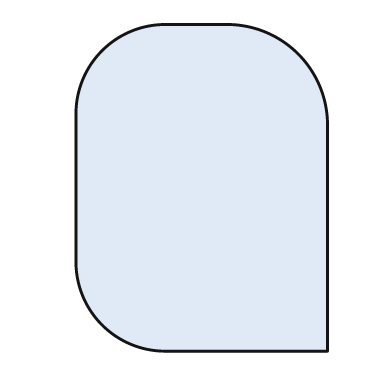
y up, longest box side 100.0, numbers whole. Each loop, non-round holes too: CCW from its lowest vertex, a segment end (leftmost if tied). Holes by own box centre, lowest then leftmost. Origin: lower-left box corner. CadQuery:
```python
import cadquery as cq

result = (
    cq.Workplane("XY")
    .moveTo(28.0, 0.0)
    .lineTo(77.0, 0.0)
    .lineTo(77.0, 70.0)
    .threePointArc((68.0, 91.0), (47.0, 100.0))
    .lineTo(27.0, 100.0)
    .threePointArc((8.0, 92.0), (0.0, 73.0))
    .lineTo(0.0, 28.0)
    .threePointArc((8.0, 8.0), (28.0, 0.0))
    .close()
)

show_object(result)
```